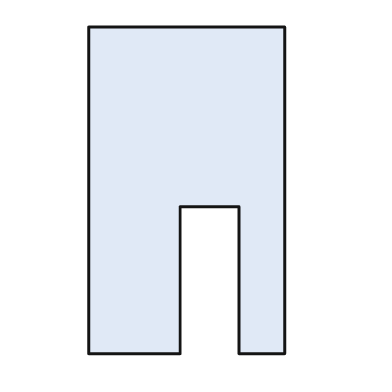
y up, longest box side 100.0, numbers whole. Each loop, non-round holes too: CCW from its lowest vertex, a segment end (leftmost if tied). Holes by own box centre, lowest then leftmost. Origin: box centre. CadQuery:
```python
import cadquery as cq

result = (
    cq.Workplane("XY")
    .moveTo(-30.0, -50.0)
    .lineTo(-2.0, -50.0)
    .lineTo(-2.0, -5.0)
    .lineTo(16.0, -5.0)
    .lineTo(16.0, -50.0)
    .lineTo(30.0, -50.0)
    .lineTo(30.0, 50.0)
    .lineTo(-30.0, 50.0)
    .close()
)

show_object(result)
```